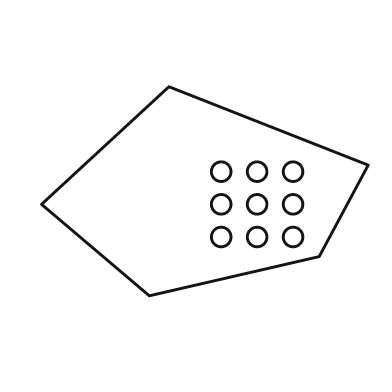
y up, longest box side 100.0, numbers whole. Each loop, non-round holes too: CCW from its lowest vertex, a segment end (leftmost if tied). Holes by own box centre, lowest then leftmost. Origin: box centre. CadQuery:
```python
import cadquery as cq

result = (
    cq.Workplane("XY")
    .moveTo(-17.0, -32.0)
    .lineTo(35.0, -20.0)
    .lineTo(50.0, 8.0)
    .lineTo(-11.0, 32.0)
    .lineTo(-50.0, -4.0)
    .close()
    .moveTo(5.0, -14.0)
    .circle(3.0)
    .moveTo(16.0, -14.0)
    .circle(3.0)
    .moveTo(27.0, -14.0)
    .circle(3.0)
    .moveTo(5.0, -4.0)
    .circle(3.0)
    .moveTo(16.0, -4.0)
    .circle(3.0)
    .moveTo(27.0, -4.0)
    .circle(3.0)
    .moveTo(5.0, 6.0)
    .circle(3.0)
    .moveTo(16.0, 6.0)
    .circle(3.0)
    .moveTo(27.0, 6.0)
    .circle(3.0)
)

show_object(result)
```